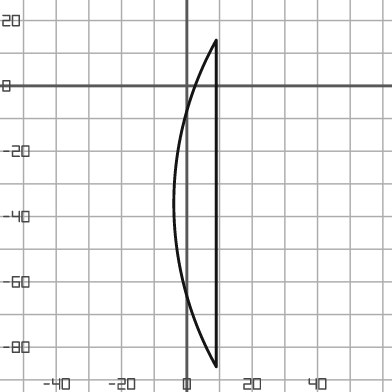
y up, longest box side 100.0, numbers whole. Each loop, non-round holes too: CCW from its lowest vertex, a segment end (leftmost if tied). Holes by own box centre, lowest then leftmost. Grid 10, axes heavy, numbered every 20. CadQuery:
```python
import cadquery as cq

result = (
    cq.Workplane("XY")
    .moveTo(9.0, -86.0)
    .lineTo(9.0, 14.0)
    .threePointArc((-4.0, -36.0), (9.0, -86.0))
    .close()
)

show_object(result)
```